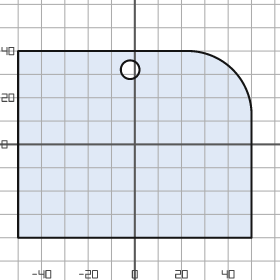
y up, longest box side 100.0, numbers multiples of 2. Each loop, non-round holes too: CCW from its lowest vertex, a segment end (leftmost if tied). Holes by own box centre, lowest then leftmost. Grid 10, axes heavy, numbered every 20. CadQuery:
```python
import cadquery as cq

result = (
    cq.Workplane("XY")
    .moveTo(-50.0, -40.0)
    .lineTo(50.0, -40.0)
    .lineTo(50.0, 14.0)
    .threePointArc((42.0, 32.0), (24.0, 40.0))
    .lineTo(-50.0, 40.0)
    .close()
    .moveTo(-2.0, 32.0)
    .circle(4.0)
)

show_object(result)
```